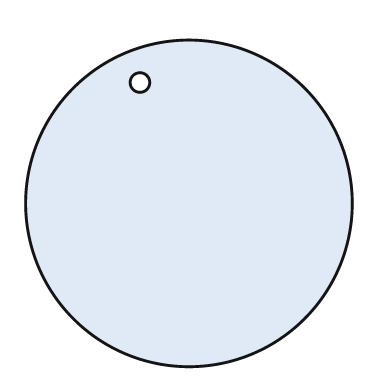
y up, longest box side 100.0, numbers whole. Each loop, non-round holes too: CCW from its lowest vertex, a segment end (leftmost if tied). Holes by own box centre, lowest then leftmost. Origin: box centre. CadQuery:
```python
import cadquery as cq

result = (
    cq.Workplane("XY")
    .moveTo(0.0, 0.0)
    .circle(50.0)
    .moveTo(-15.0, 37.0)
    .circle(3.0)
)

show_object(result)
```